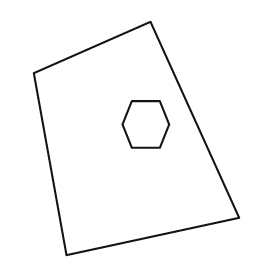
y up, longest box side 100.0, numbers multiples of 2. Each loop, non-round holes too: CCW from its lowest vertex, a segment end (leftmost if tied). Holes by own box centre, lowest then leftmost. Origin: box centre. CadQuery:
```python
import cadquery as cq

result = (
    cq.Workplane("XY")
    .moveTo(-30.0, -50.0)
    .lineTo(44.0, -34.0)
    .lineTo(6.0, 50.0)
    .lineTo(-44.0, 28.0)
    .close()
    .moveTo(-2.0, -4.0)
    .lineTo(10.0, -4.0)
    .lineTo(14.0, 6.0)
    .lineTo(10.0, 16.0)
    .lineTo(-2.0, 16.0)
    .lineTo(-6.0, 6.0)
    .close()
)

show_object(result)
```